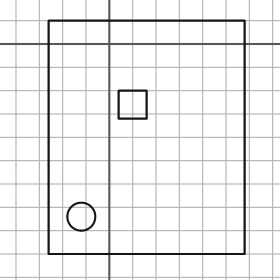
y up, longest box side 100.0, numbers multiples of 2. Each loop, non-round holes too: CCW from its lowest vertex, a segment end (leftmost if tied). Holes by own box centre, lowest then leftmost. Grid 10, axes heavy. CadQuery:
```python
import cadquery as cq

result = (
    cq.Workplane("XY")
    .moveTo(-26.0, -90.0)
    .lineTo(58.0, -90.0)
    .lineTo(58.0, 10.0)
    .lineTo(-26.0, 10.0)
    .close()
    .moveTo(-12.0, -74.0)
    .circle(6.0)
    .moveTo(4.0, -32.0)
    .lineTo(16.0, -32.0)
    .lineTo(16.0, -20.0)
    .lineTo(4.0, -20.0)
    .close()
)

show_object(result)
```